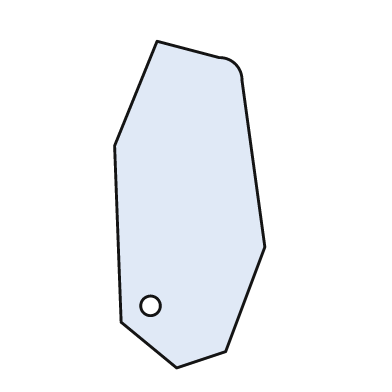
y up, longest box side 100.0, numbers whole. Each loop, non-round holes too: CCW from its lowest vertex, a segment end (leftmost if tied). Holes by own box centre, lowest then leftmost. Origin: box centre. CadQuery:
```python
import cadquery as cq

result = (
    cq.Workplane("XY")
    .moveTo(-4.0, -50.0)
    .lineTo(11.0, -45.0)
    .lineTo(23.0, -13.0)
    .lineTo(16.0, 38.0)
    .threePointArc((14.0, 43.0), (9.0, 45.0))
    .lineTo(-10.0, 50.0)
    .lineTo(-23.0, 18.0)
    .lineTo(-21.0, -36.0)
    .close()
    .moveTo(-12.0, -31.0)
    .circle(3.0)
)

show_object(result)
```